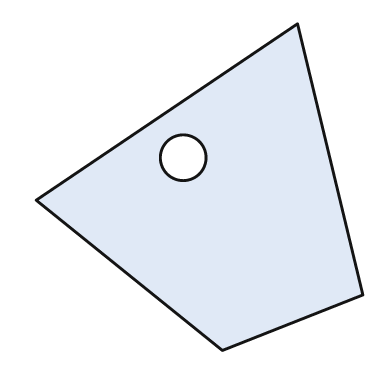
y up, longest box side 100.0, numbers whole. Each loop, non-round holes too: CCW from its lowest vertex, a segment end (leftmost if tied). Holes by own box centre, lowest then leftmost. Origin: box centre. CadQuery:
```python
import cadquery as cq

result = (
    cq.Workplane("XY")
    .moveTo(7.0, -50.0)
    .lineTo(50.0, -33.0)
    .lineTo(30.0, 50.0)
    .lineTo(-50.0, -4.0)
    .close()
    .moveTo(-5.0, 9.0)
    .circle(7.0)
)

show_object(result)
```